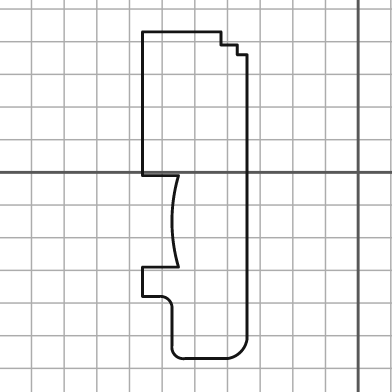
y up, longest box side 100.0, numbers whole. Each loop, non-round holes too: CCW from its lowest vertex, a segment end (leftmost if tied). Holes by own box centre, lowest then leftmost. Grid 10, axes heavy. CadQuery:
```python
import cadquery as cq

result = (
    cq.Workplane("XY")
    .moveTo(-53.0, -57.0)
    .lineTo(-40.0, -57.0)
    .threePointArc((-36.0, -55.0), (-34.0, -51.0))
    .lineTo(-34.0, 36.0)
    .lineTo(-37.0, 36.0)
    .lineTo(-37.0, 39.0)
    .lineTo(-42.0, 39.0)
    .lineTo(-42.0, 43.0)
    .lineTo(-66.0, 43.0)
    .lineTo(-66.0, -1.0)
    .lineTo(-55.0, -1.0)
    .threePointArc((-57.0, -15.0), (-55.0, -29.0))
    .lineTo(-66.0, -29.0)
    .lineTo(-66.0, -38.0)
    .lineTo(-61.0, -38.0)
    .threePointArc((-58.0, -39.0), (-57.0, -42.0))
    .lineTo(-57.0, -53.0)
    .threePointArc((-56.0, -56.0), (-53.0, -57.0))
    .close()
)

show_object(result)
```